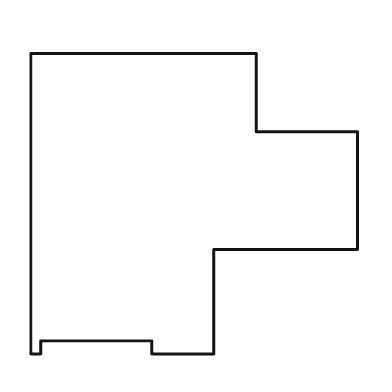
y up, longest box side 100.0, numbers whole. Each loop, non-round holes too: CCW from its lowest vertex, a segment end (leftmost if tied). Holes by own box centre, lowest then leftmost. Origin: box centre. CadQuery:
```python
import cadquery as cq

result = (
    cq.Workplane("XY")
    .moveTo(-50.0, -46.0)
    .lineTo(-47.0, -46.0)
    .lineTo(-47.0, -42.0)
    .lineTo(-13.0, -42.0)
    .lineTo(-13.0, -46.0)
    .lineTo(6.0, -46.0)
    .lineTo(6.0, -14.0)
    .lineTo(50.0, -14.0)
    .lineTo(50.0, 22.0)
    .lineTo(19.0, 22.0)
    .lineTo(19.0, 46.0)
    .lineTo(-50.0, 46.0)
    .close()
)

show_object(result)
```